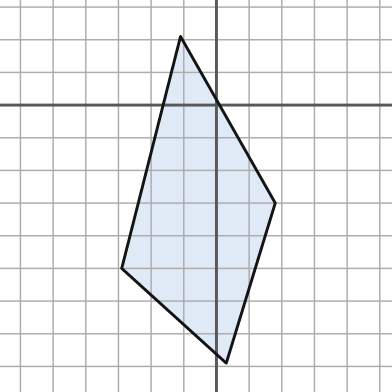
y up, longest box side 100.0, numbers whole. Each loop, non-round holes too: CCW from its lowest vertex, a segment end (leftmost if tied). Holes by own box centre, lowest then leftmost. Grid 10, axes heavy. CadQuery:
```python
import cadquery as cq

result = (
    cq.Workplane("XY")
    .moveTo(3.0, -79.0)
    .lineTo(18.0, -30.0)
    .lineTo(-11.0, 21.0)
    .lineTo(-29.0, -50.0)
    .close()
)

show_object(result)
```